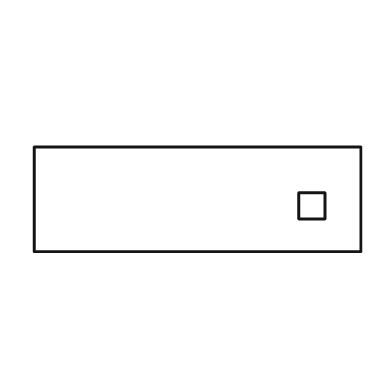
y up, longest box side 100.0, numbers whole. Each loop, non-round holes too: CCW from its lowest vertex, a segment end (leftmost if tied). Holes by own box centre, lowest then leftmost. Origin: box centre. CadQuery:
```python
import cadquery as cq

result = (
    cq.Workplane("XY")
    .moveTo(-50.0, -16.0)
    .lineTo(50.0, -16.0)
    .lineTo(50.0, 16.0)
    .lineTo(-50.0, 16.0)
    .close()
    .moveTo(31.0, -6.0)
    .lineTo(39.0, -6.0)
    .lineTo(39.0, 2.0)
    .lineTo(31.0, 2.0)
    .close()
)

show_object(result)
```